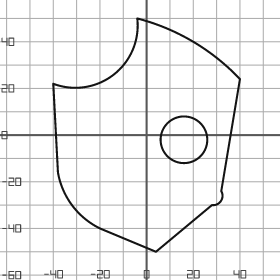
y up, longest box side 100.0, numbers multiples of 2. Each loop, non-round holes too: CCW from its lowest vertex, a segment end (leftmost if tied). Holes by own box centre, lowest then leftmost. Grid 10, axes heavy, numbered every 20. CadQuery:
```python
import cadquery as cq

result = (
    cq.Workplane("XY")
    .moveTo(4.0, -50.0)
    .lineTo(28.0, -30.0)
    .threePointArc((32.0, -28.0), (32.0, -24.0))
    .lineTo(40.0, 24.0)
    .threePointArc((20.0, 40.0), (-4.0, 50.0))
    .threePointArc((-14.0, 26.0), (-40.0, 22.0))
    .lineTo(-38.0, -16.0)
    .threePointArc((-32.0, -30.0), (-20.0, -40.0))
    .close()
    .moveTo(16.0, -2.0)
    .circle(10.0)
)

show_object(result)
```